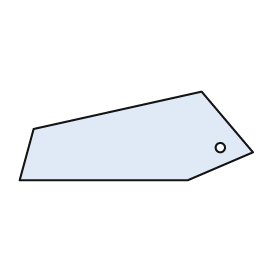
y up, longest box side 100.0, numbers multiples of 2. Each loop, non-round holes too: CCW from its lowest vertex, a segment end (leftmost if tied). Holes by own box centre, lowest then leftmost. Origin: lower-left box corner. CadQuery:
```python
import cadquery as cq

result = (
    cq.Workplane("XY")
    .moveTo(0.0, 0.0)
    .lineTo(72.0, 0.0)
    .lineTo(100.0, 12.0)
    .lineTo(78.0, 38.0)
    .lineTo(6.0, 22.0)
    .close()
    .moveTo(86.0, 14.0)
    .circle(2.0)
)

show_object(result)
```